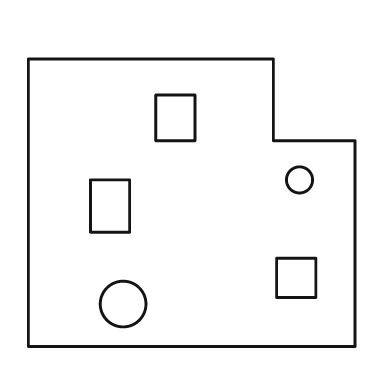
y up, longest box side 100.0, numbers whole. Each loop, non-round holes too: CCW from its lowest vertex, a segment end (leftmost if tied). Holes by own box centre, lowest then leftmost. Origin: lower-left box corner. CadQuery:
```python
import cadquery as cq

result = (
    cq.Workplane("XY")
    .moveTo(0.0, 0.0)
    .lineTo(100.0, 0.0)
    .lineTo(100.0, 63.0)
    .lineTo(75.0, 63.0)
    .lineTo(75.0, 88.0)
    .lineTo(0.0, 88.0)
    .close()
    .moveTo(29.0, 13.0)
    .circle(7.0)
    .moveTo(76.0, 15.0)
    .lineTo(88.0, 15.0)
    .lineTo(88.0, 27.0)
    .lineTo(76.0, 27.0)
    .close()
    .moveTo(19.0, 35.0)
    .lineTo(31.0, 35.0)
    .lineTo(31.0, 51.0)
    .lineTo(19.0, 51.0)
    .close()
    .moveTo(83.0, 51.0)
    .circle(4.0)
    .moveTo(39.0, 63.0)
    .lineTo(51.0, 63.0)
    .lineTo(51.0, 77.0)
    .lineTo(39.0, 77.0)
    .close()
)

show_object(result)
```